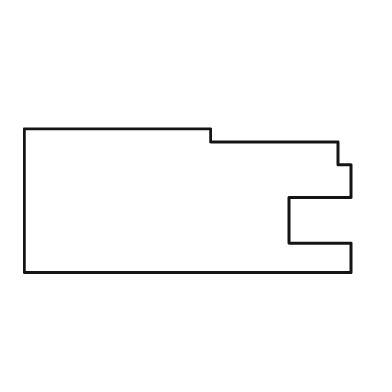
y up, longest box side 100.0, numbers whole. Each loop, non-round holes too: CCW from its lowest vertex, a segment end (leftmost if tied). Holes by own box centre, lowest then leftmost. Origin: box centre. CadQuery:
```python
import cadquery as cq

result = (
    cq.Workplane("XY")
    .moveTo(-50.0, -22.0)
    .lineTo(50.0, -22.0)
    .lineTo(50.0, -13.0)
    .lineTo(31.0, -13.0)
    .lineTo(31.0, 1.0)
    .lineTo(50.0, 1.0)
    .lineTo(50.0, 11.0)
    .lineTo(46.0, 11.0)
    .lineTo(46.0, 18.0)
    .lineTo(7.0, 18.0)
    .lineTo(7.0, 22.0)
    .lineTo(-50.0, 22.0)
    .close()
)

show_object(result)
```